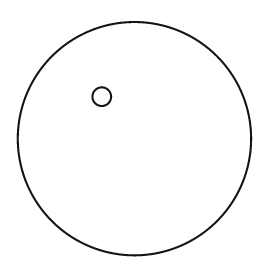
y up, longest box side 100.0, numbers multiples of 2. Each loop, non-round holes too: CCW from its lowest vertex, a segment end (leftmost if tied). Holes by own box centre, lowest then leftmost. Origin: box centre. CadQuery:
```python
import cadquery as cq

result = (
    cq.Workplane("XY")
    .moveTo(0.0, 0.0)
    .circle(50.0)
    .moveTo(-14.0, 18.0)
    .circle(4.0)
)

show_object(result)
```